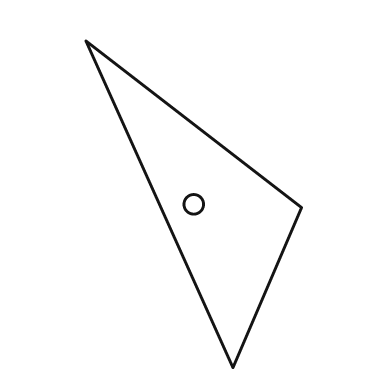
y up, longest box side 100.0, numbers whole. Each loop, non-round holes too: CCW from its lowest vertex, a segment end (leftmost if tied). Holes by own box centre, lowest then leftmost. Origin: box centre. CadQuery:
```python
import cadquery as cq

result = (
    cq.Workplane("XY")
    .moveTo(12.0, -50.0)
    .lineTo(33.0, -1.0)
    .lineTo(-33.0, 50.0)
    .close()
    .moveTo(0.0, 0.0)
    .circle(3.0)
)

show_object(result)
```